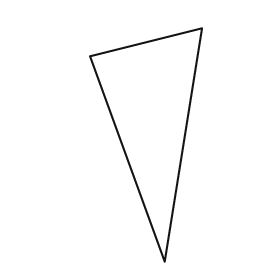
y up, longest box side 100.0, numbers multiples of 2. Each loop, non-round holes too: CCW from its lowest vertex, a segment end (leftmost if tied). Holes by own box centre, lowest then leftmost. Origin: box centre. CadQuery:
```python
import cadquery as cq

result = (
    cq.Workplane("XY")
    .moveTo(8.0, -50.0)
    .lineTo(24.0, 50.0)
    .lineTo(-24.0, 38.0)
    .close()
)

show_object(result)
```